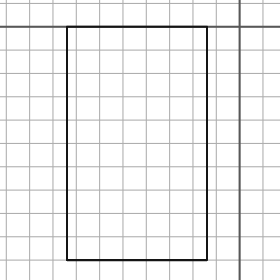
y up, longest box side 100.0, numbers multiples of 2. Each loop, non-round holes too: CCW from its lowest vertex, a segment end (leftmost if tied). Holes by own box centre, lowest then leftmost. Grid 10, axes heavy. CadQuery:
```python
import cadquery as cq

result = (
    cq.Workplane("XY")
    .moveTo(-74.0, -100.0)
    .lineTo(-14.0, -100.0)
    .lineTo(-14.0, 0.0)
    .lineTo(-74.0, 0.0)
    .close()
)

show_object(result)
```